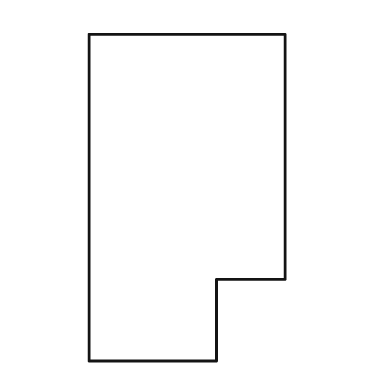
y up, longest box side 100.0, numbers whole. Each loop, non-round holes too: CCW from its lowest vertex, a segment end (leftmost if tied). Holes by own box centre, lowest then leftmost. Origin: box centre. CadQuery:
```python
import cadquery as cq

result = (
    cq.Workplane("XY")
    .moveTo(-30.0, -50.0)
    .lineTo(9.0, -50.0)
    .lineTo(9.0, -25.0)
    .lineTo(30.0, -25.0)
    .lineTo(30.0, 50.0)
    .lineTo(-30.0, 50.0)
    .close()
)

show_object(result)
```